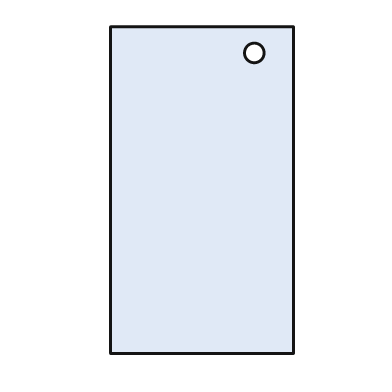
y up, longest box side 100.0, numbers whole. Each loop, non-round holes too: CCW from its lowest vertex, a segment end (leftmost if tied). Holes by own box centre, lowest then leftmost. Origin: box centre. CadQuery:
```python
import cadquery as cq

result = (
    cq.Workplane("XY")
    .moveTo(-28.0, -50.0)
    .lineTo(28.0, -50.0)
    .lineTo(28.0, 50.0)
    .lineTo(-28.0, 50.0)
    .close()
    .moveTo(16.0, 42.0)
    .circle(3.0)
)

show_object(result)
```